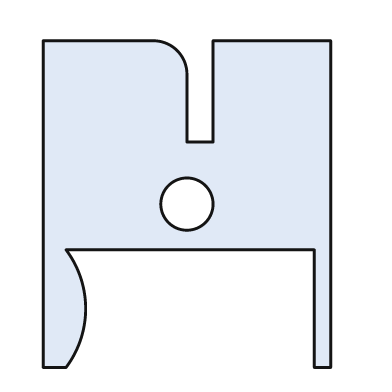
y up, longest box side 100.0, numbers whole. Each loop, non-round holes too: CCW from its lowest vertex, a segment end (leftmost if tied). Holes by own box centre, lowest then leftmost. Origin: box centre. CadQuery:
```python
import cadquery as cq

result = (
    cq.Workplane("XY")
    .moveTo(-44.0, -50.0)
    .lineTo(-37.0, -50.0)
    .threePointArc((-31.0, -32.0), (-37.0, -14.0))
    .lineTo(39.0, -14.0)
    .lineTo(39.0, -50.0)
    .lineTo(44.0, -50.0)
    .lineTo(44.0, 50.0)
    .lineTo(8.0, 50.0)
    .lineTo(8.0, 19.0)
    .lineTo(0.0, 19.0)
    .lineTo(0.0, 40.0)
    .threePointArc((-3.0, 47.0), (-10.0, 50.0))
    .lineTo(-44.0, 50.0)
    .close()
    .moveTo(0.0, 0.0)
    .circle(8.0)
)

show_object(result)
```